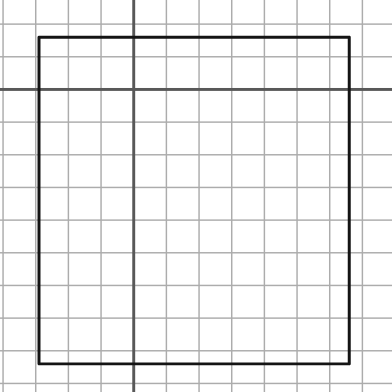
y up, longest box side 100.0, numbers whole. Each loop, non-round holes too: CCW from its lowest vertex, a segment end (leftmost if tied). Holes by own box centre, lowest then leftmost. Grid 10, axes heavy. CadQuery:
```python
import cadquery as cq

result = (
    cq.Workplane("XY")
    .moveTo(-29.0, -84.0)
    .lineTo(66.0, -84.0)
    .lineTo(66.0, 16.0)
    .lineTo(-29.0, 16.0)
    .close()
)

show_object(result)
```